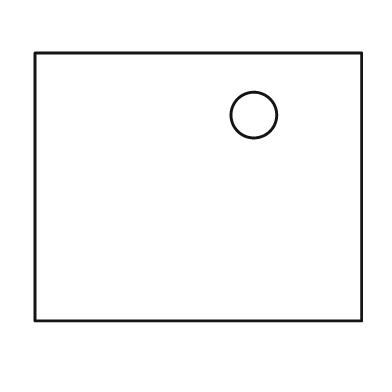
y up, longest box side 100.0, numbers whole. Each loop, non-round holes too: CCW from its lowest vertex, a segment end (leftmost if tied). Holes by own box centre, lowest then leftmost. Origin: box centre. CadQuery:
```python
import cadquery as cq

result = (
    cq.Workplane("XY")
    .moveTo(-50.0, -41.0)
    .lineTo(50.0, -41.0)
    .lineTo(50.0, 41.0)
    .lineTo(-50.0, 41.0)
    .close()
    .moveTo(17.0, 22.0)
    .circle(7.0)
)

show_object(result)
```